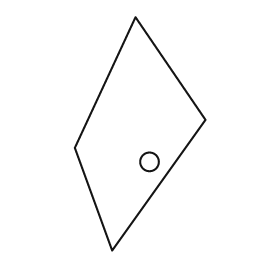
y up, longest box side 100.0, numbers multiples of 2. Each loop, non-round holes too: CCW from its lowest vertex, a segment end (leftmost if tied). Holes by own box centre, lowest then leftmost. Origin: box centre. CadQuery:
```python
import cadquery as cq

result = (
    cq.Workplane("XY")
    .moveTo(-12.0, -50.0)
    .lineTo(28.0, 6.0)
    .lineTo(-2.0, 50.0)
    .lineTo(-28.0, -6.0)
    .close()
    .moveTo(4.0, -12.0)
    .circle(4.0)
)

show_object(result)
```